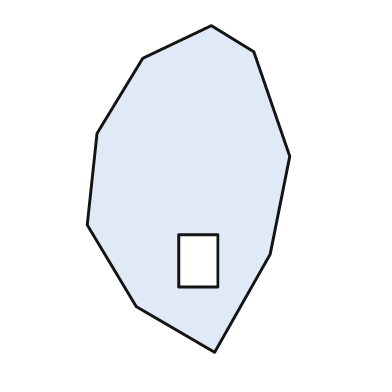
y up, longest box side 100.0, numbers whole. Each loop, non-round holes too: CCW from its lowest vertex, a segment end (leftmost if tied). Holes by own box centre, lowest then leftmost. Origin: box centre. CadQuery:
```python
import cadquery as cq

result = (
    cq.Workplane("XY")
    .moveTo(8.0, -50.0)
    .lineTo(25.0, -20.0)
    .lineTo(31.0, 10.0)
    .lineTo(20.0, 42.0)
    .lineTo(7.0, 50.0)
    .lineTo(-14.0, 40.0)
    .lineTo(-28.0, 17.0)
    .lineTo(-31.0, -11.0)
    .lineTo(-16.0, -36.0)
    .close()
    .moveTo(-3.0, -30.0)
    .lineTo(9.0, -30.0)
    .lineTo(9.0, -14.0)
    .lineTo(-3.0, -14.0)
    .close()
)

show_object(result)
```